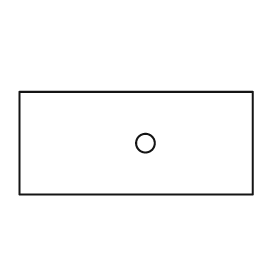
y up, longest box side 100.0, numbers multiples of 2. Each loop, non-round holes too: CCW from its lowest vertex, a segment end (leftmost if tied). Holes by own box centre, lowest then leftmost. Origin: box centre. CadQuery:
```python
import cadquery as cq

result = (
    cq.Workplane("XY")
    .moveTo(-50.0, -22.0)
    .lineTo(50.0, -22.0)
    .lineTo(50.0, 22.0)
    .lineTo(-50.0, 22.0)
    .close()
    .moveTo(4.0, 0.0)
    .circle(4.0)
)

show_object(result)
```